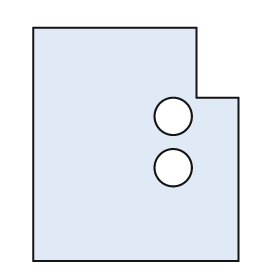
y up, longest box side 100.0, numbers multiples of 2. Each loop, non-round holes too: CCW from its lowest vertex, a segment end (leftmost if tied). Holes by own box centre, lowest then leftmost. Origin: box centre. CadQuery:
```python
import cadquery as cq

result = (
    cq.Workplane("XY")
    .moveTo(-44.0, -50.0)
    .lineTo(44.0, -50.0)
    .lineTo(44.0, 20.0)
    .lineTo(26.0, 20.0)
    .lineTo(26.0, 50.0)
    .lineTo(-44.0, 50.0)
    .close()
    .moveTo(16.0, -10.0)
    .circle(8.0)
    .moveTo(16.0, 12.0)
    .circle(8.0)
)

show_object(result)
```